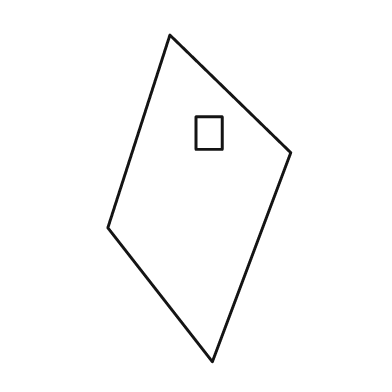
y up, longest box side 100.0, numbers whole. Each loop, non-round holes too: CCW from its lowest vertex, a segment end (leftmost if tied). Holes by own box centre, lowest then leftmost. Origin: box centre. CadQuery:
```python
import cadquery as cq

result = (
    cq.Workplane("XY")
    .moveTo(4.0, -50.0)
    .lineTo(28.0, 14.0)
    .lineTo(-9.0, 50.0)
    .lineTo(-28.0, -9.0)
    .close()
    .moveTo(-1.0, 15.0)
    .lineTo(7.0, 15.0)
    .lineTo(7.0, 25.0)
    .lineTo(-1.0, 25.0)
    .close()
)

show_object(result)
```